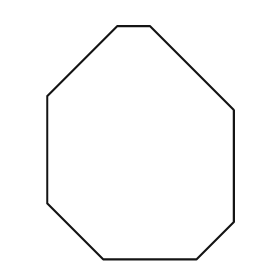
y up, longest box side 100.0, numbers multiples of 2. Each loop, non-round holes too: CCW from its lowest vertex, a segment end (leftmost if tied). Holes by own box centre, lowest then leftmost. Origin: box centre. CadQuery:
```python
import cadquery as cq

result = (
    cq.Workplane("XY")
    .moveTo(-16.0, -50.0)
    .lineTo(24.0, -50.0)
    .lineTo(40.0, -34.0)
    .lineTo(40.0, 14.0)
    .lineTo(4.0, 50.0)
    .lineTo(-10.0, 50.0)
    .lineTo(-40.0, 20.0)
    .lineTo(-40.0, -26.0)
    .close()
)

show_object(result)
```